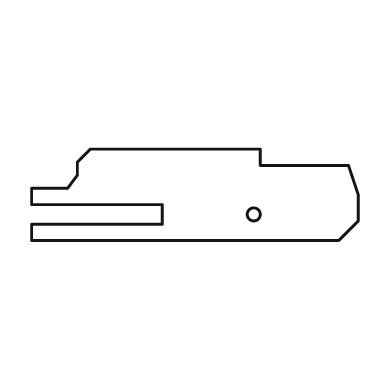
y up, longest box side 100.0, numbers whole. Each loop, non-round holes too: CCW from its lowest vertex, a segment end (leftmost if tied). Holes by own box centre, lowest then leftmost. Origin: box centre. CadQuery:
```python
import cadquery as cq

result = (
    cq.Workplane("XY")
    .moveTo(-50.0, -14.0)
    .lineTo(44.0, -14.0)
    .lineTo(50.0, -8.0)
    .lineTo(50.0, 0.0)
    .lineTo(47.0, 9.0)
    .lineTo(20.0, 9.0)
    .lineTo(20.0, 14.0)
    .lineTo(-32.0, 14.0)
    .lineTo(-36.0, 10.0)
    .lineTo(-36.0, 6.0)
    .lineTo(-39.0, 2.0)
    .lineTo(-50.0, 2.0)
    .lineTo(-50.0, -3.0)
    .lineTo(-10.0, -3.0)
    .lineTo(-10.0, -9.0)
    .lineTo(-50.0, -9.0)
    .close()
    .moveTo(18.0, -6.0)
    .circle(2.0)
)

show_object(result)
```